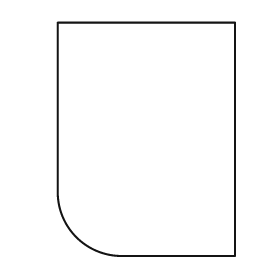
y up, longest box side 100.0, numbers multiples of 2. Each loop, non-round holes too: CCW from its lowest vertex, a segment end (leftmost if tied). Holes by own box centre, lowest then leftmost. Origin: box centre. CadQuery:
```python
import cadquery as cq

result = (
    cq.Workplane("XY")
    .moveTo(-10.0, -50.0)
    .lineTo(38.0, -50.0)
    .lineTo(38.0, 50.0)
    .lineTo(-38.0, 50.0)
    .lineTo(-38.0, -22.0)
    .threePointArc((-30.0, -42.0), (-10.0, -50.0))
    .close()
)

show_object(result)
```